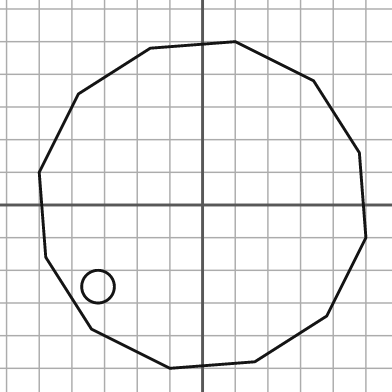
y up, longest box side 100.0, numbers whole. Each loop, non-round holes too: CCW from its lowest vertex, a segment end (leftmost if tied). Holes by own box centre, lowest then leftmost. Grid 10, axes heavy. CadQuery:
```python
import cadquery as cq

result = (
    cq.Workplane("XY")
    .moveTo(-10.0, -50.0)
    .lineTo(16.0, -48.0)
    .lineTo(38.0, -34.0)
    .lineTo(50.0, -10.0)
    .lineTo(48.0, 16.0)
    .lineTo(34.0, 38.0)
    .lineTo(10.0, 50.0)
    .lineTo(-16.0, 48.0)
    .lineTo(-38.0, 34.0)
    .lineTo(-50.0, 10.0)
    .lineTo(-48.0, -16.0)
    .lineTo(-34.0, -38.0)
    .close()
    .moveTo(-32.0, -25.0)
    .circle(5.0)
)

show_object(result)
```